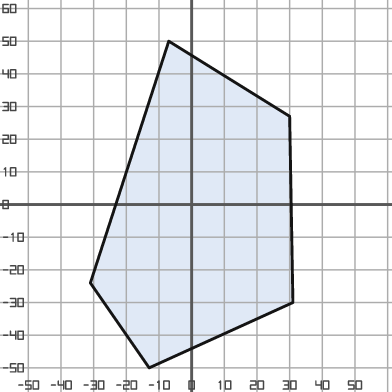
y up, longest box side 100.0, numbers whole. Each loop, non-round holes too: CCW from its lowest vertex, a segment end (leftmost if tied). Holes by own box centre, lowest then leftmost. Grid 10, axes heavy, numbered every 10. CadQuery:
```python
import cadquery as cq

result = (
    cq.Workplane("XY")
    .moveTo(-13.0, -50.0)
    .lineTo(31.0, -30.0)
    .lineTo(30.0, 27.0)
    .lineTo(-7.0, 50.0)
    .lineTo(-31.0, -24.0)
    .close()
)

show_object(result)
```